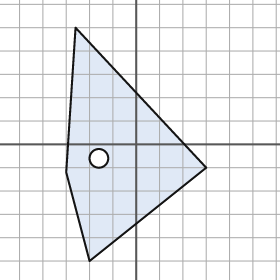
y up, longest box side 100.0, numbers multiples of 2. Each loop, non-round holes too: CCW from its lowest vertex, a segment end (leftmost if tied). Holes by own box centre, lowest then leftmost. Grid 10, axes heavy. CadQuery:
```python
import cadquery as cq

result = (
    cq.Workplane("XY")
    .moveTo(-20.0, -50.0)
    .lineTo(30.0, -10.0)
    .lineTo(-26.0, 50.0)
    .lineTo(-30.0, -12.0)
    .close()
    .moveTo(-16.0, -6.0)
    .circle(4.0)
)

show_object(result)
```